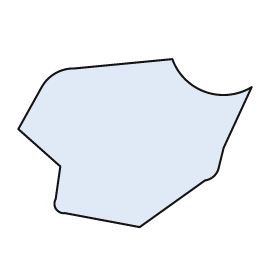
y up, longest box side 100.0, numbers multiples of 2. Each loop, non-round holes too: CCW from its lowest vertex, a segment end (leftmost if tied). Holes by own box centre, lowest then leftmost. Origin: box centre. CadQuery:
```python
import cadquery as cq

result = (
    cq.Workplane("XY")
    .moveTo(2.0, -36.0)
    .lineTo(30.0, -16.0)
    .threePointArc((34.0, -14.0), (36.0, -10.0))
    .lineTo(38.0, -2.0)
    .lineTo(50.0, 24.0)
    .threePointArc((30.0, 22.0), (16.0, 36.0))
    .lineTo(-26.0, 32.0)
    .threePointArc((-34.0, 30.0), (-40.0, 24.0))
    .lineTo(-50.0, 6.0)
    .lineTo(-32.0, -10.0)
    .lineTo(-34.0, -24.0)
    .threePointArc((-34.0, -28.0), (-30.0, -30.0))
    .close()
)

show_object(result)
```